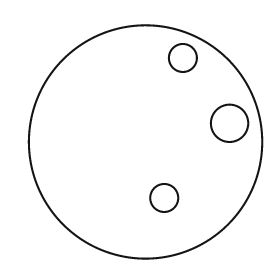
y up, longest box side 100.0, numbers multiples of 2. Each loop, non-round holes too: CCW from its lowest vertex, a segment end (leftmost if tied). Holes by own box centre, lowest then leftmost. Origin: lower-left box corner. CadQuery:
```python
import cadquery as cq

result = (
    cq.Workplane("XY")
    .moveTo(50.0, 50.0)
    .circle(50.0)
    .moveTo(58.0, 26.0)
    .circle(6.0)
    .moveTo(86.0, 58.0)
    .circle(8.0)
    .moveTo(66.0, 86.0)
    .circle(6.0)
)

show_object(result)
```